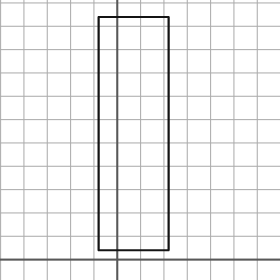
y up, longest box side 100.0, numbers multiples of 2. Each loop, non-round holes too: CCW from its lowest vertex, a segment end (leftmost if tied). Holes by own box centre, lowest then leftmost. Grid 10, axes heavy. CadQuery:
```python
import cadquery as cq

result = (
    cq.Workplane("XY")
    .moveTo(-8.0, 4.0)
    .lineTo(22.0, 4.0)
    .lineTo(22.0, 104.0)
    .lineTo(-8.0, 104.0)
    .close()
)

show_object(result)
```